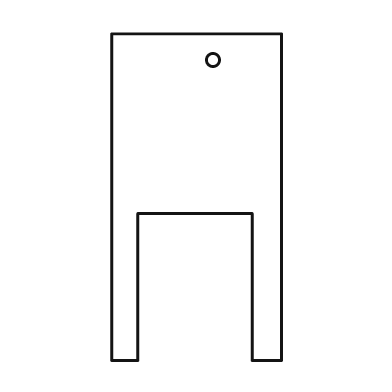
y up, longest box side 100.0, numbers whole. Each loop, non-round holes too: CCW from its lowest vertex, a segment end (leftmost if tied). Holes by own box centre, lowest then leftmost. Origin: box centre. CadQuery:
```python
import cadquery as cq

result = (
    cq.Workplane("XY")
    .moveTo(-26.0, -50.0)
    .lineTo(-18.0, -50.0)
    .lineTo(-18.0, -5.0)
    .lineTo(17.0, -5.0)
    .lineTo(17.0, -50.0)
    .lineTo(26.0, -50.0)
    .lineTo(26.0, 50.0)
    .lineTo(-26.0, 50.0)
    .close()
    .moveTo(5.0, 42.0)
    .circle(2.0)
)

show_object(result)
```